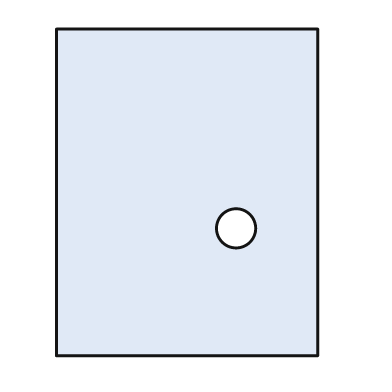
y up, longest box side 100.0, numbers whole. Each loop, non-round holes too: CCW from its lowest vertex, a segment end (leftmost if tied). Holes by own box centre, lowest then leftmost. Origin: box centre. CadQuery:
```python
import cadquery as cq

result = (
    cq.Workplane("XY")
    .moveTo(-40.0, -50.0)
    .lineTo(40.0, -50.0)
    .lineTo(40.0, 50.0)
    .lineTo(-40.0, 50.0)
    .close()
    .moveTo(15.0, -11.0)
    .circle(6.0)
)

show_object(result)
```